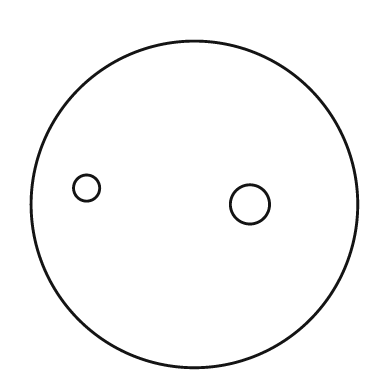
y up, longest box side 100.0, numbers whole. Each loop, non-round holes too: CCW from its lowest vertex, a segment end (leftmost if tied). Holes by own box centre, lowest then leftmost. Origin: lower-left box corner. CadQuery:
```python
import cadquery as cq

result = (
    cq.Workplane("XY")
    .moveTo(50.0, 50.0)
    .circle(50.0)
    .moveTo(67.0, 50.0)
    .circle(6.0)
    .moveTo(17.0, 55.0)
    .circle(4.0)
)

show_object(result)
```